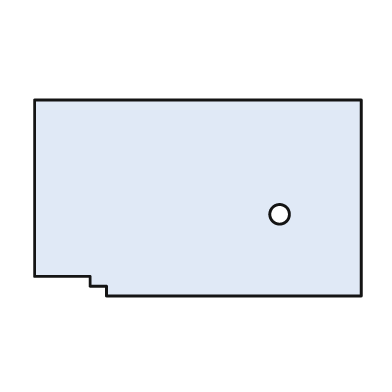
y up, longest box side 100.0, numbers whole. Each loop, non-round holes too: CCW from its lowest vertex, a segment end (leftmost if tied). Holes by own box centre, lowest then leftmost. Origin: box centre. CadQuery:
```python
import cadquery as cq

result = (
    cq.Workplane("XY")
    .moveTo(-28.0, -30.0)
    .lineTo(50.0, -30.0)
    .lineTo(50.0, 30.0)
    .lineTo(-50.0, 30.0)
    .lineTo(-50.0, -24.0)
    .lineTo(-33.0, -24.0)
    .lineTo(-33.0, -27.0)
    .lineTo(-28.0, -27.0)
    .close()
    .moveTo(25.0, -5.0)
    .circle(3.0)
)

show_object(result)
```